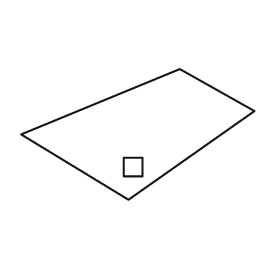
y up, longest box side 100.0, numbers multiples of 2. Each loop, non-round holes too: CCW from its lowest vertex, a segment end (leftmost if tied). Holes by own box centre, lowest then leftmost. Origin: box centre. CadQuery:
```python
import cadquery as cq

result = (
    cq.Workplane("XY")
    .moveTo(-4.0, -28.0)
    .lineTo(50.0, 10.0)
    .lineTo(18.0, 28.0)
    .lineTo(-50.0, 0.0)
    .close()
    .moveTo(-6.0, -18.0)
    .lineTo(2.0, -18.0)
    .lineTo(2.0, -10.0)
    .lineTo(-6.0, -10.0)
    .close()
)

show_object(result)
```